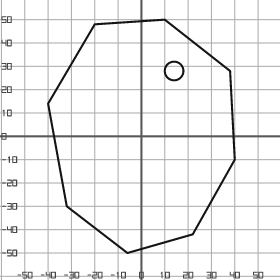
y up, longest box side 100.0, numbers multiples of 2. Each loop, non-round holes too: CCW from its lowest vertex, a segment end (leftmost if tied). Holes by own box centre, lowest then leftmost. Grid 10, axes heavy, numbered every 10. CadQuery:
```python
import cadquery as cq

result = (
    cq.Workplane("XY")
    .moveTo(-6.0, -50.0)
    .lineTo(22.0, -42.0)
    .lineTo(40.0, -10.0)
    .lineTo(38.0, 28.0)
    .lineTo(10.0, 50.0)
    .lineTo(-20.0, 48.0)
    .lineTo(-40.0, 14.0)
    .lineTo(-32.0, -30.0)
    .close()
    .moveTo(14.0, 28.0)
    .circle(4.0)
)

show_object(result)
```